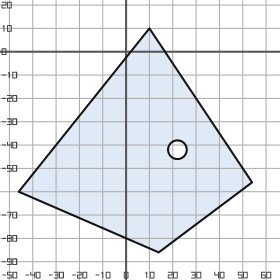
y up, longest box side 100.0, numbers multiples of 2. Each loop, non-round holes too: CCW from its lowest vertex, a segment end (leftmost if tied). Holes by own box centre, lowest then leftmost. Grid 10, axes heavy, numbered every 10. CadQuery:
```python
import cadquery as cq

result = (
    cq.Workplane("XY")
    .moveTo(14.0, -86.0)
    .lineTo(54.0, -56.0)
    .lineTo(10.0, 10.0)
    .lineTo(-46.0, -60.0)
    .close()
    .moveTo(22.0, -42.0)
    .circle(4.0)
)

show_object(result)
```